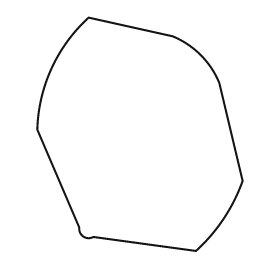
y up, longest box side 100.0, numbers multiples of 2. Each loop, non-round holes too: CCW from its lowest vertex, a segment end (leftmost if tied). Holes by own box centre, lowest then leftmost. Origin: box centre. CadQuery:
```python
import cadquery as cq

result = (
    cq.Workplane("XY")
    .moveTo(24.0, -50.0)
    .threePointArc((36.0, -36.0), (44.0, -20.0))
    .lineTo(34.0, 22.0)
    .threePointArc((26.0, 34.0), (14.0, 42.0))
    .lineTo(-22.0, 50.0)
    .threePointArc((-38.0, 28.0), (-44.0, 2.0))
    .lineTo(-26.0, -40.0)
    .threePointArc((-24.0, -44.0), (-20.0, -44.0))
    .close()
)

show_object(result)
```